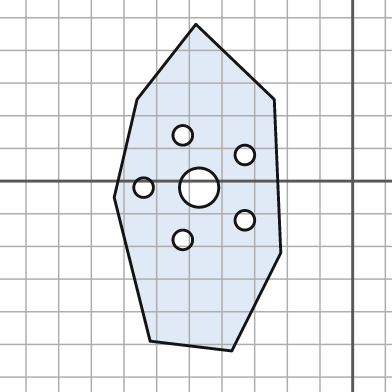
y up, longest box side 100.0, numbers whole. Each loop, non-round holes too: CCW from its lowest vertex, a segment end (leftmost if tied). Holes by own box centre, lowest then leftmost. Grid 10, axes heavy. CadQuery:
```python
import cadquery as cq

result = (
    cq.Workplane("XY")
    .moveTo(-37.0, -52.0)
    .lineTo(-22.0, -22.0)
    .lineTo(-24.0, 25.0)
    .lineTo(-48.0, 48.0)
    .lineTo(-66.0, 25.0)
    .lineTo(-73.0, -5.0)
    .lineTo(-62.0, -49.0)
    .close()
    .moveTo(-52.0, -18.0)
    .circle(3.0)
    .moveTo(-33.0, -12.0)
    .circle(3.0)
    .moveTo(-64.0, -2.0)
    .circle(3.0)
    .moveTo(-47.0, -2.0)
    .circle(6.0)
    .moveTo(-33.0, 8.0)
    .circle(3.0)
    .moveTo(-52.0, 14.0)
    .circle(3.0)
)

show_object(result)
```